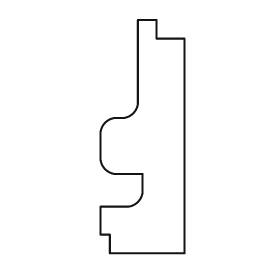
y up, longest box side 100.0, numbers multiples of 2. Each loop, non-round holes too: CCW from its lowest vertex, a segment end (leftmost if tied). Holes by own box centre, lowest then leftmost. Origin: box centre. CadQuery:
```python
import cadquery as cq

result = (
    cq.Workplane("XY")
    .moveTo(-14.0, -50.0)
    .lineTo(18.0, -50.0)
    .lineTo(18.0, 42.0)
    .lineTo(6.0, 42.0)
    .lineTo(6.0, 50.0)
    .lineTo(-2.0, 50.0)
    .lineTo(-2.0, 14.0)
    .threePointArc((-4.0, 10.0), (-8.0, 8.0))
    .lineTo(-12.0, 8.0)
    .threePointArc((-16.0, 6.0), (-18.0, 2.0))
    .lineTo(-18.0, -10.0)
    .threePointArc((-16.0, -14.0), (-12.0, -16.0))
    .lineTo(0.0, -16.0)
    .lineTo(0.0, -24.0)
    .threePointArc((-2.0, -28.0), (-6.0, -30.0))
    .lineTo(-18.0, -30.0)
    .lineTo(-18.0, -42.0)
    .lineTo(-14.0, -42.0)
    .close()
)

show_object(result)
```